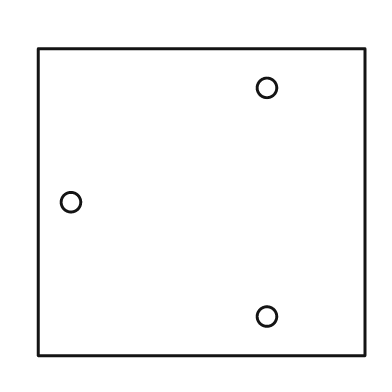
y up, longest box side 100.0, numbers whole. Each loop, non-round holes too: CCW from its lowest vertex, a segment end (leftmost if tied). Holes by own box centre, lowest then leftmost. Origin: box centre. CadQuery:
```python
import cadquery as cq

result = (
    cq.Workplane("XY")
    .moveTo(-50.0, -47.0)
    .lineTo(50.0, -47.0)
    .lineTo(50.0, 47.0)
    .lineTo(-50.0, 47.0)
    .close()
    .moveTo(20.0, -35.0)
    .circle(3.0)
    .moveTo(-40.0, 0.0)
    .circle(3.0)
    .moveTo(20.0, 35.0)
    .circle(3.0)
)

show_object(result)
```